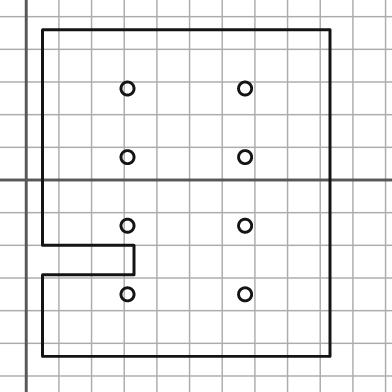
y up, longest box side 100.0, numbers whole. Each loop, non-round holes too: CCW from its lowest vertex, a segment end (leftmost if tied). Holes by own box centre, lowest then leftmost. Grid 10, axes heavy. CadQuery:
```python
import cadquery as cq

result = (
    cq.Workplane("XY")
    .moveTo(5.0, -54.0)
    .lineTo(93.0, -54.0)
    .lineTo(93.0, 46.0)
    .lineTo(5.0, 46.0)
    .lineTo(5.0, -20.0)
    .lineTo(33.0, -20.0)
    .lineTo(33.0, -29.0)
    .lineTo(5.0, -29.0)
    .close()
    .moveTo(31.0, -35.0)
    .circle(2.0)
    .moveTo(67.0, -35.0)
    .circle(2.0)
    .moveTo(31.0, -14.0)
    .circle(2.0)
    .moveTo(67.0, -14.0)
    .circle(2.0)
    .moveTo(31.0, 7.0)
    .circle(2.0)
    .moveTo(67.0, 7.0)
    .circle(2.0)
    .moveTo(31.0, 28.0)
    .circle(2.0)
    .moveTo(67.0, 28.0)
    .circle(2.0)
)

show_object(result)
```